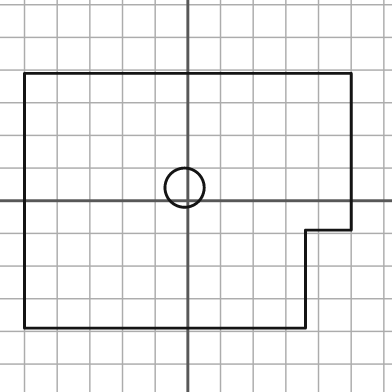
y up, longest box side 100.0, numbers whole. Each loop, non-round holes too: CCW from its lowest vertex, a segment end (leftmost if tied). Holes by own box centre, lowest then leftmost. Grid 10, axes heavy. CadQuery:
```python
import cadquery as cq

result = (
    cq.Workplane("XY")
    .moveTo(-50.0, -39.0)
    .lineTo(36.0, -39.0)
    .lineTo(36.0, -9.0)
    .lineTo(50.0, -9.0)
    .lineTo(50.0, 39.0)
    .lineTo(-50.0, 39.0)
    .close()
    .moveTo(-1.0, 4.0)
    .circle(6.0)
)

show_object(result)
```